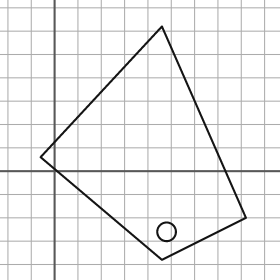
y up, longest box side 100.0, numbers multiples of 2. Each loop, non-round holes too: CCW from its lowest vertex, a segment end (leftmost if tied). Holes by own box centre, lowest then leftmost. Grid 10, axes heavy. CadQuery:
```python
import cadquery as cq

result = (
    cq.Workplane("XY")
    .moveTo(46.0, -38.0)
    .lineTo(82.0, -20.0)
    .lineTo(46.0, 62.0)
    .lineTo(-6.0, 6.0)
    .close()
    .moveTo(48.0, -26.0)
    .circle(4.0)
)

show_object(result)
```